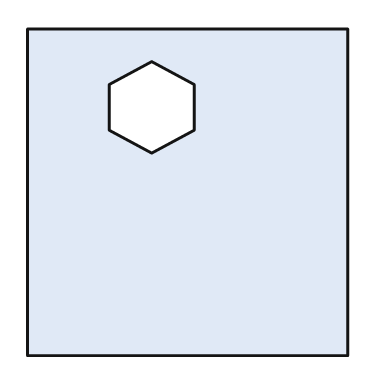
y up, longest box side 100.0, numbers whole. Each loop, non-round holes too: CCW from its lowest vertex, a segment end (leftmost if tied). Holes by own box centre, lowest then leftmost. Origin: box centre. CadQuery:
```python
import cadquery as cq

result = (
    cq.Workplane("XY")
    .moveTo(-49.0, -50.0)
    .lineTo(49.0, -50.0)
    .lineTo(49.0, 50.0)
    .lineTo(-49.0, 50.0)
    .close()
    .moveTo(-11.0, 12.0)
    .lineTo(2.0, 19.0)
    .lineTo(2.0, 33.0)
    .lineTo(-11.0, 40.0)
    .lineTo(-24.0, 33.0)
    .lineTo(-24.0, 19.0)
    .close()
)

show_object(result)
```